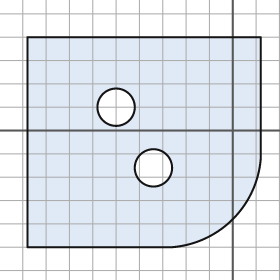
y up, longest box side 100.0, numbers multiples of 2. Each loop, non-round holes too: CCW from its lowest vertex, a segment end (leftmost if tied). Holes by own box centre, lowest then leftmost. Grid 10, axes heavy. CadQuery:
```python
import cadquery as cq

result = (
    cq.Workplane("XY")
    .moveTo(-88.0, -50.0)
    .lineTo(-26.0, -50.0)
    .threePointArc((0.0, -38.0), (12.0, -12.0))
    .lineTo(12.0, 40.0)
    .lineTo(-88.0, 40.0)
    .close()
    .moveTo(-34.0, -16.0)
    .circle(8.0)
    .moveTo(-50.0, 10.0)
    .circle(8.0)
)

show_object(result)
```